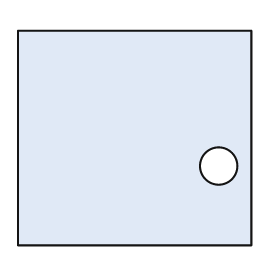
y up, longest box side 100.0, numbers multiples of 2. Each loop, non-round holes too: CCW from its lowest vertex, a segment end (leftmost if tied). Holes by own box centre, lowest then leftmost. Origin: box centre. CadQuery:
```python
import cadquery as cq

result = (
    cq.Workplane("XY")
    .moveTo(-50.0, -46.0)
    .lineTo(50.0, -46.0)
    .lineTo(50.0, 46.0)
    .lineTo(-50.0, 46.0)
    .close()
    .moveTo(36.0, -12.0)
    .circle(8.0)
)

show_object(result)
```